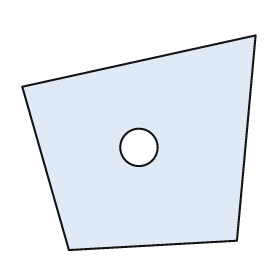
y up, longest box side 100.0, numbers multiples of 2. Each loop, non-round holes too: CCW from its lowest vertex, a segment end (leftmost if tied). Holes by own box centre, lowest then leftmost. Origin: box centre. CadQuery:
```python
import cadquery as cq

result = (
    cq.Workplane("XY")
    .moveTo(-30.0, -46.0)
    .lineTo(42.0, -42.0)
    .lineTo(50.0, 46.0)
    .lineTo(-50.0, 24.0)
    .close()
    .moveTo(0.0, -2.0)
    .circle(8.0)
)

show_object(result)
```